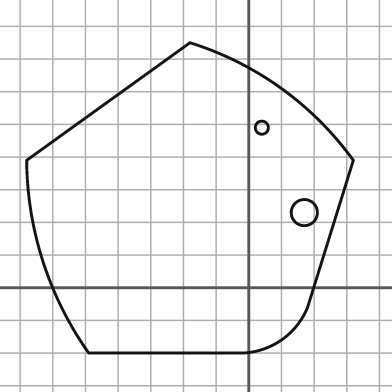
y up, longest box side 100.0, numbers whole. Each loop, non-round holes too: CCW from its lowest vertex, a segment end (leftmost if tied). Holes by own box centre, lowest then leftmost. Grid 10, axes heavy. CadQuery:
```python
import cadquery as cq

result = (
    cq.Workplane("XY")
    .moveTo(-49.0, -20.0)
    .lineTo(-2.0, -20.0)
    .threePointArc((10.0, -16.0), (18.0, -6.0))
    .lineTo(32.0, 39.0)
    .threePointArc((10.0, 61.0), (-18.0, 75.0))
    .lineTo(-68.0, 39.0)
    .threePointArc((-63.0, 8.0), (-49.0, -20.0))
    .close()
    .moveTo(17.0, 23.0)
    .circle(4.0)
    .moveTo(4.0, 49.0)
    .circle(2.0)
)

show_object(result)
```